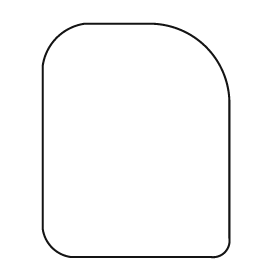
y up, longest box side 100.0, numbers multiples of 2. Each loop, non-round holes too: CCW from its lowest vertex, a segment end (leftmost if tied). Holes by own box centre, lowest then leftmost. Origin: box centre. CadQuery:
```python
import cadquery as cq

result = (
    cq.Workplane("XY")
    .moveTo(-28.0, -50.0)
    .lineTo(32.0, -50.0)
    .threePointArc((38.0, -48.0), (40.0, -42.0))
    .lineTo(40.0, 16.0)
    .threePointArc((30.0, 40.0), (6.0, 50.0))
    .lineTo(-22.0, 50.0)
    .threePointArc((-34.0, 44.0), (-40.0, 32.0))
    .lineTo(-40.0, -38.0)
    .threePointArc((-36.0, -46.0), (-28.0, -50.0))
    .close()
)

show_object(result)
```